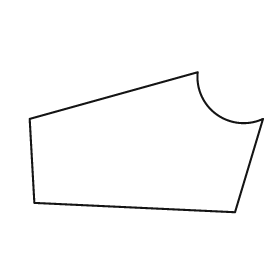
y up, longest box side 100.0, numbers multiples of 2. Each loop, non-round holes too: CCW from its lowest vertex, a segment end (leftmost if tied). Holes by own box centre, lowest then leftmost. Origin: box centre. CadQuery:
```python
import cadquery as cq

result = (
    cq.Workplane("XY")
    .moveTo(38.0, -30.0)
    .lineTo(50.0, 10.0)
    .threePointArc((30.0, 12.0), (22.0, 30.0))
    .lineTo(-50.0, 10.0)
    .lineTo(-48.0, -26.0)
    .close()
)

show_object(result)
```